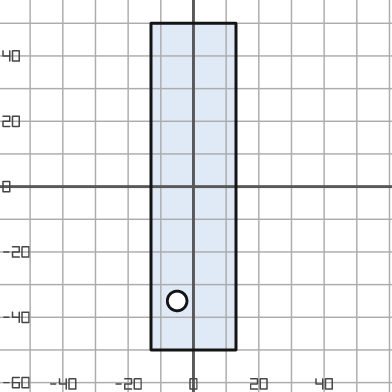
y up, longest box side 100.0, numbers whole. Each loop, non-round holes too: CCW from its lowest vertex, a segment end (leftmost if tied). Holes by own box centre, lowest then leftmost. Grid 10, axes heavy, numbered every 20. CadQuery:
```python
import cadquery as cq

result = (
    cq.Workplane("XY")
    .moveTo(-13.0, -50.0)
    .lineTo(13.0, -50.0)
    .lineTo(13.0, 50.0)
    .lineTo(-13.0, 50.0)
    .close()
    .moveTo(-5.0, -35.0)
    .circle(3.0)
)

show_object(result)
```